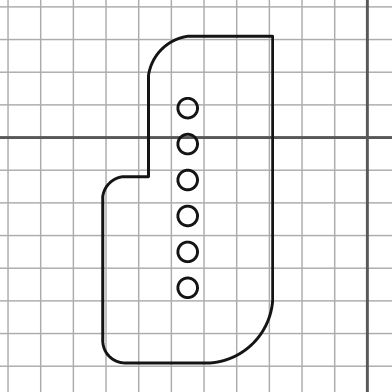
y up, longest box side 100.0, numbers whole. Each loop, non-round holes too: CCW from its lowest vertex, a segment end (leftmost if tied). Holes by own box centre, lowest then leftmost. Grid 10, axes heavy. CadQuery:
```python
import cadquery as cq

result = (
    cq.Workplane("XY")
    .moveTo(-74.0, -69.0)
    .lineTo(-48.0, -69.0)
    .threePointArc((-35.0, -63.0), (-29.0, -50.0))
    .lineTo(-29.0, 31.0)
    .lineTo(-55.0, 31.0)
    .threePointArc((-63.0, 27.0), (-67.0, 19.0))
    .lineTo(-67.0, -12.0)
    .lineTo(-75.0, -12.0)
    .threePointArc((-79.0, -14.0), (-81.0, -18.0))
    .lineTo(-81.0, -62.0)
    .threePointArc((-79.0, -67.0), (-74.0, -69.0))
    .close()
    .moveTo(-55.0, -46.0)
    .circle(3.0)
    .moveTo(-55.0, -35.0)
    .circle(3.0)
    .moveTo(-55.0, -24.0)
    .circle(3.0)
    .moveTo(-55.0, -13.0)
    .circle(3.0)
    .moveTo(-55.0, -2.0)
    .circle(3.0)
    .moveTo(-55.0, 9.0)
    .circle(3.0)
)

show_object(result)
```